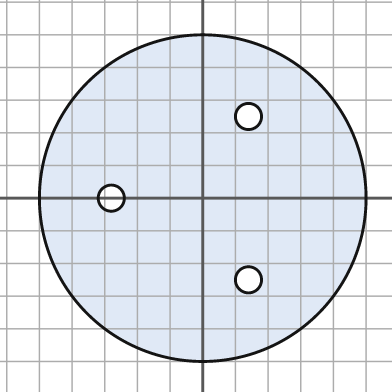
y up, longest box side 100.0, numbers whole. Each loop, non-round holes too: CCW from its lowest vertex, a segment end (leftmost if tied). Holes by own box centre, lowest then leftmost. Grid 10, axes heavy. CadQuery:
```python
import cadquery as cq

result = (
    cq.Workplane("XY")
    .moveTo(0.0, 0.0)
    .circle(50.0)
    .moveTo(14.0, -25.0)
    .circle(4.0)
    .moveTo(-28.0, 0.0)
    .circle(4.0)
    .moveTo(14.0, 25.0)
    .circle(4.0)
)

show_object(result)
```